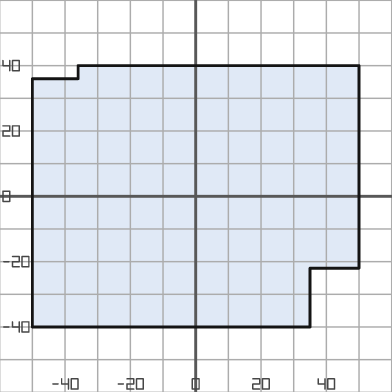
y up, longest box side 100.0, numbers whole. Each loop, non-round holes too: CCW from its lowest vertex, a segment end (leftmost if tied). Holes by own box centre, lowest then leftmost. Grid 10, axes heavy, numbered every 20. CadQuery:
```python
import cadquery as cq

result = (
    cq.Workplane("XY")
    .moveTo(-50.0, -40.0)
    .lineTo(35.0, -40.0)
    .lineTo(35.0, -22.0)
    .lineTo(50.0, -22.0)
    .lineTo(50.0, 40.0)
    .lineTo(-36.0, 40.0)
    .lineTo(-36.0, 36.0)
    .lineTo(-50.0, 36.0)
    .close()
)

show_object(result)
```